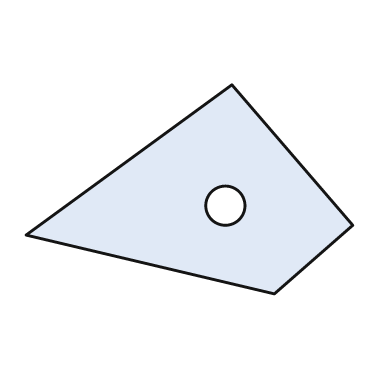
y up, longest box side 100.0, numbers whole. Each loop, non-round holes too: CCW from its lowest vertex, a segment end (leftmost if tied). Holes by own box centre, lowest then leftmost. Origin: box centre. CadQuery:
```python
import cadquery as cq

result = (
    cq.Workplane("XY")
    .moveTo(26.0, -32.0)
    .lineTo(50.0, -11.0)
    .lineTo(13.0, 32.0)
    .lineTo(-50.0, -14.0)
    .close()
    .moveTo(11.0, -5.0)
    .circle(6.0)
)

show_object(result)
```